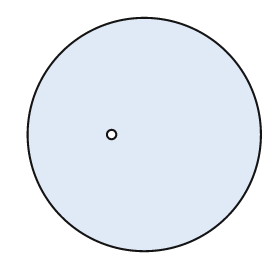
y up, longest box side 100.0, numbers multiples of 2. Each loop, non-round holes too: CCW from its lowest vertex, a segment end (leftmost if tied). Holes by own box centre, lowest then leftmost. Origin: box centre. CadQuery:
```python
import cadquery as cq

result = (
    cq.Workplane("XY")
    .moveTo(0.0, 0.0)
    .circle(50.0)
    .moveTo(-14.0, 0.0)
    .circle(2.0)
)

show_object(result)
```